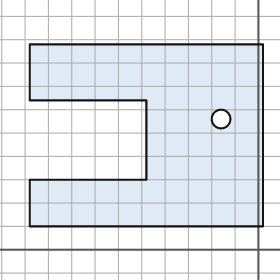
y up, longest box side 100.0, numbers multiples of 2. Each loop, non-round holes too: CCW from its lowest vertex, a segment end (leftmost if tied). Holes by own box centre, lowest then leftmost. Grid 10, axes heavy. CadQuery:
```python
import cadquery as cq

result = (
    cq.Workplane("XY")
    .moveTo(-98.0, 10.0)
    .lineTo(2.0, 10.0)
    .lineTo(2.0, 88.0)
    .lineTo(-98.0, 88.0)
    .lineTo(-98.0, 64.0)
    .lineTo(-48.0, 64.0)
    .lineTo(-48.0, 30.0)
    .lineTo(-98.0, 30.0)
    .close()
    .moveTo(-16.0, 56.0)
    .circle(4.0)
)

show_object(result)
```